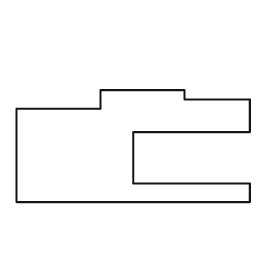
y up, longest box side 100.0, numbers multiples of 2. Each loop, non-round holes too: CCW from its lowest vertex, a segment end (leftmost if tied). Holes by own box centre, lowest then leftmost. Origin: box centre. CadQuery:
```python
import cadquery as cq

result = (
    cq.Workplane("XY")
    .moveTo(-50.0, -24.0)
    .lineTo(50.0, -24.0)
    .lineTo(50.0, -16.0)
    .lineTo(0.0, -16.0)
    .lineTo(0.0, 6.0)
    .lineTo(50.0, 6.0)
    .lineTo(50.0, 20.0)
    .lineTo(22.0, 20.0)
    .lineTo(22.0, 24.0)
    .lineTo(-14.0, 24.0)
    .lineTo(-14.0, 16.0)
    .lineTo(-50.0, 16.0)
    .close()
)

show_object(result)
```